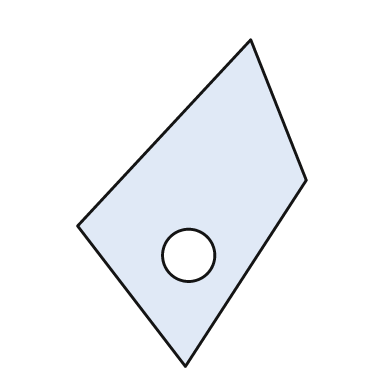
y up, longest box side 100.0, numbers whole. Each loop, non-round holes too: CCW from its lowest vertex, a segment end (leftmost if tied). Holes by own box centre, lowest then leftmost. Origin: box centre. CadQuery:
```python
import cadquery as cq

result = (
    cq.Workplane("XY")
    .moveTo(-2.0, -50.0)
    .lineTo(35.0, 7.0)
    .lineTo(18.0, 50.0)
    .lineTo(-35.0, -7.0)
    .close()
    .moveTo(-1.0, -16.0)
    .circle(8.0)
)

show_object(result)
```